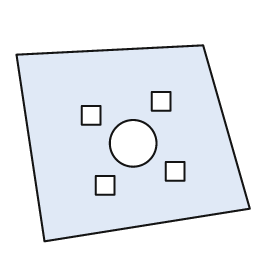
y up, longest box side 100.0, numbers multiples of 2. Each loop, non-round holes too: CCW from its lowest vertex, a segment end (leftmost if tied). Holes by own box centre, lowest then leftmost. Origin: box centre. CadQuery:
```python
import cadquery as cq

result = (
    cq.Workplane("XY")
    .moveTo(-38.0, -42.0)
    .lineTo(50.0, -28.0)
    .lineTo(30.0, 42.0)
    .lineTo(-50.0, 38.0)
    .close()
    .moveTo(-16.0, -22.0)
    .lineTo(-8.0, -22.0)
    .lineTo(-8.0, -14.0)
    .lineTo(-16.0, -14.0)
    .close()
    .moveTo(14.0, -16.0)
    .lineTo(22.0, -16.0)
    .lineTo(22.0, -8.0)
    .lineTo(14.0, -8.0)
    .close()
    .moveTo(0.0, 0.0)
    .circle(10.0)
    .moveTo(-22.0, 8.0)
    .lineTo(-14.0, 8.0)
    .lineTo(-14.0, 16.0)
    .lineTo(-22.0, 16.0)
    .close()
    .moveTo(8.0, 14.0)
    .lineTo(16.0, 14.0)
    .lineTo(16.0, 22.0)
    .lineTo(8.0, 22.0)
    .close()
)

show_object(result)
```